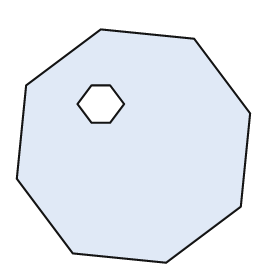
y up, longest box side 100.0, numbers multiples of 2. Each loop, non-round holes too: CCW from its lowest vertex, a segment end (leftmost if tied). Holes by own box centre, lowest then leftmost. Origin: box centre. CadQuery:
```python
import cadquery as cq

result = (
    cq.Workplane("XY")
    .moveTo(14.0, -50.0)
    .lineTo(46.0, -26.0)
    .lineTo(50.0, 14.0)
    .lineTo(26.0, 46.0)
    .lineTo(-14.0, 50.0)
    .lineTo(-46.0, 26.0)
    .lineTo(-50.0, -14.0)
    .lineTo(-26.0, -46.0)
    .close()
    .moveTo(-18.0, 10.0)
    .lineTo(-10.0, 10.0)
    .lineTo(-4.0, 18.0)
    .lineTo(-10.0, 26.0)
    .lineTo(-18.0, 26.0)
    .lineTo(-24.0, 18.0)
    .close()
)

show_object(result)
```